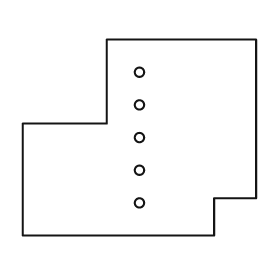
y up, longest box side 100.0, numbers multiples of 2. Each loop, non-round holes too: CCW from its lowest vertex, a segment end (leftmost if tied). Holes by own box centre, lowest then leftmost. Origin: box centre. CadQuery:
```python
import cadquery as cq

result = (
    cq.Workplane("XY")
    .moveTo(-50.0, -42.0)
    .lineTo(32.0, -42.0)
    .lineTo(32.0, -26.0)
    .lineTo(50.0, -26.0)
    .lineTo(50.0, 42.0)
    .lineTo(-14.0, 42.0)
    .lineTo(-14.0, 6.0)
    .lineTo(-50.0, 6.0)
    .close()
    .moveTo(0.0, -28.0)
    .circle(2.0)
    .moveTo(0.0, -14.0)
    .circle(2.0)
    .moveTo(0.0, 0.0)
    .circle(2.0)
    .moveTo(0.0, 14.0)
    .circle(2.0)
    .moveTo(0.0, 28.0)
    .circle(2.0)
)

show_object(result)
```